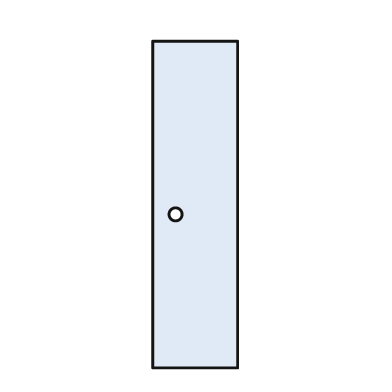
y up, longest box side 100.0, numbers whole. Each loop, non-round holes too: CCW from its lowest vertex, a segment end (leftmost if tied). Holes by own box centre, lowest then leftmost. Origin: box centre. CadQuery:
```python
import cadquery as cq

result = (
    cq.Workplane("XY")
    .moveTo(-13.0, -50.0)
    .lineTo(13.0, -50.0)
    .lineTo(13.0, 50.0)
    .lineTo(-13.0, 50.0)
    .close()
    .moveTo(-6.0, -3.0)
    .circle(2.0)
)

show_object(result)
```